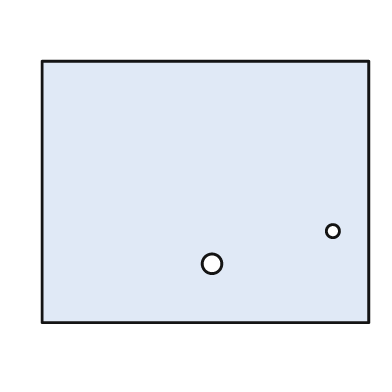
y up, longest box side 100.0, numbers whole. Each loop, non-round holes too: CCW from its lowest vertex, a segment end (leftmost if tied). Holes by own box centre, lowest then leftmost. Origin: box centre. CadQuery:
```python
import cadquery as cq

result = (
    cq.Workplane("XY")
    .moveTo(-50.0, -40.0)
    .lineTo(50.0, -40.0)
    .lineTo(50.0, 40.0)
    .lineTo(-50.0, 40.0)
    .close()
    .moveTo(2.0, -22.0)
    .circle(3.0)
    .moveTo(39.0, -12.0)
    .circle(2.0)
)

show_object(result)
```